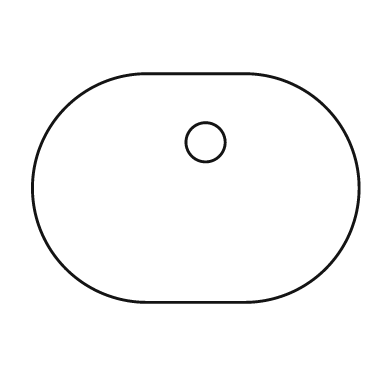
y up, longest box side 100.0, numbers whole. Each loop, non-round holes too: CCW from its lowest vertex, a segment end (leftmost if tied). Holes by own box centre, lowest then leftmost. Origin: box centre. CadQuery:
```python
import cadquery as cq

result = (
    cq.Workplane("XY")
    .moveTo(-15.0, -35.0)
    .lineTo(15.0, -35.0)
    .threePointArc((50.0, 0.0), (15.0, 35.0))
    .lineTo(-15.0, 35.0)
    .threePointArc((-50.0, 0.0), (-15.0, -35.0))
    .close()
    .moveTo(3.0, 14.0)
    .circle(6.0)
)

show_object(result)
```